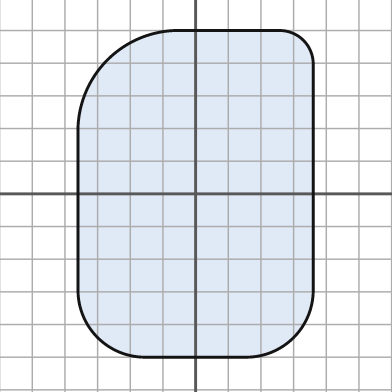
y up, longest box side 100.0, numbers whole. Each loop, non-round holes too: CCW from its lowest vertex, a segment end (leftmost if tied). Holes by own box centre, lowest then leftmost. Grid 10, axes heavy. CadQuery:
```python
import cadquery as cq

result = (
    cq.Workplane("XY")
    .moveTo(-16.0, -50.0)
    .lineTo(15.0, -50.0)
    .threePointArc((30.0, -44.0), (36.0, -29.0))
    .lineTo(36.0, 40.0)
    .threePointArc((33.0, 47.0), (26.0, 50.0))
    .lineTo(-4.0, 50.0)
    .threePointArc((-27.0, 41.0), (-36.0, 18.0))
    .lineTo(-36.0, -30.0)
    .threePointArc((-30.0, -44.0), (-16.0, -50.0))
    .close()
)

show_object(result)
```